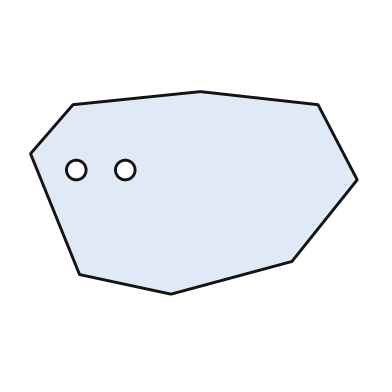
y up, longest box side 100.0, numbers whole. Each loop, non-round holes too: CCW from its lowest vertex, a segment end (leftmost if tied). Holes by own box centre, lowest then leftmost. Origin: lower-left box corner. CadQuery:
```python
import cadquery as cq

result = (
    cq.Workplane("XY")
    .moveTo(43.0, 0.0)
    .lineTo(80.0, 10.0)
    .lineTo(100.0, 35.0)
    .lineTo(88.0, 58.0)
    .lineTo(52.0, 62.0)
    .lineTo(13.0, 58.0)
    .lineTo(0.0, 43.0)
    .lineTo(15.0, 6.0)
    .close()
    .moveTo(14.0, 38.0)
    .circle(3.0)
    .moveTo(29.0, 38.0)
    .circle(3.0)
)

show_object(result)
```